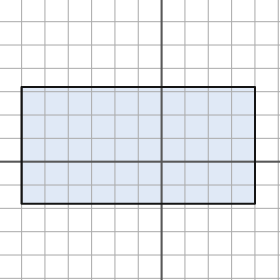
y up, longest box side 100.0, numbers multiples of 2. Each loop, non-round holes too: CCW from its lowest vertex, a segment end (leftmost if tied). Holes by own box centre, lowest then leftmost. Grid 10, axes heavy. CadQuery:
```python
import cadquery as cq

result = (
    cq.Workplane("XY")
    .moveTo(-60.0, -18.0)
    .lineTo(40.0, -18.0)
    .lineTo(40.0, 32.0)
    .lineTo(-60.0, 32.0)
    .close()
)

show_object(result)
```